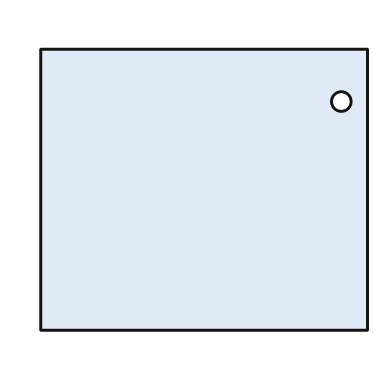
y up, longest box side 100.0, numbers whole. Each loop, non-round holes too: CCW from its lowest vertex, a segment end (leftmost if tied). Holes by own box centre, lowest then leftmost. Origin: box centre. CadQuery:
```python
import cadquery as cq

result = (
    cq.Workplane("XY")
    .moveTo(-50.0, -43.0)
    .lineTo(50.0, -43.0)
    .lineTo(50.0, 43.0)
    .lineTo(-50.0, 43.0)
    .close()
    .moveTo(42.0, 27.0)
    .circle(3.0)
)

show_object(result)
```